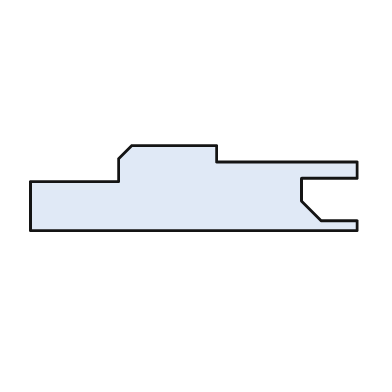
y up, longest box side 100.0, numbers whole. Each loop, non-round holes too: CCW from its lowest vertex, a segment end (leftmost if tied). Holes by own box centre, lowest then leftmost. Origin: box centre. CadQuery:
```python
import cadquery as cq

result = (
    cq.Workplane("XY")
    .moveTo(-50.0, -13.0)
    .lineTo(50.0, -13.0)
    .lineTo(50.0, -10.0)
    .lineTo(39.0, -10.0)
    .lineTo(33.0, -4.0)
    .lineTo(33.0, 3.0)
    .lineTo(50.0, 3.0)
    .lineTo(50.0, 8.0)
    .lineTo(7.0, 8.0)
    .lineTo(7.0, 13.0)
    .lineTo(-19.0, 13.0)
    .lineTo(-23.0, 9.0)
    .lineTo(-23.0, 2.0)
    .lineTo(-50.0, 2.0)
    .close()
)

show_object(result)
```